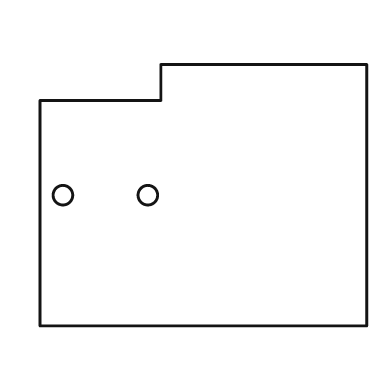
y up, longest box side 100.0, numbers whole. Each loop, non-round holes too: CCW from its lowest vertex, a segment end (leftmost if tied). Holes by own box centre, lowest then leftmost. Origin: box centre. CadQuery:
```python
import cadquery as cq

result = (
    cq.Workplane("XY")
    .moveTo(-50.0, -40.0)
    .lineTo(50.0, -40.0)
    .lineTo(50.0, 40.0)
    .lineTo(-13.0, 40.0)
    .lineTo(-13.0, 29.0)
    .lineTo(-50.0, 29.0)
    .close()
    .moveTo(-43.0, 0.0)
    .circle(3.0)
    .moveTo(-17.0, 0.0)
    .circle(3.0)
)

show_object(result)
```